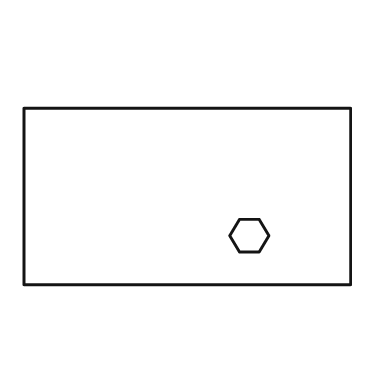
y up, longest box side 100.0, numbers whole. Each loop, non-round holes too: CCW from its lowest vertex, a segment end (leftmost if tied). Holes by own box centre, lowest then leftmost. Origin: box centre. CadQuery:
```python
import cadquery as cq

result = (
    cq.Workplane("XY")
    .moveTo(-50.0, -27.0)
    .lineTo(50.0, -27.0)
    .lineTo(50.0, 27.0)
    .lineTo(-50.0, 27.0)
    .close()
    .moveTo(16.0, -17.0)
    .lineTo(22.0, -17.0)
    .lineTo(25.0, -12.0)
    .lineTo(22.0, -7.0)
    .lineTo(16.0, -7.0)
    .lineTo(13.0, -12.0)
    .close()
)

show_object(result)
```